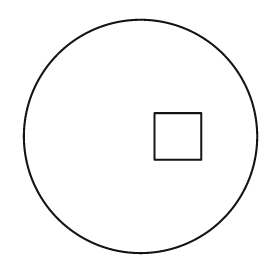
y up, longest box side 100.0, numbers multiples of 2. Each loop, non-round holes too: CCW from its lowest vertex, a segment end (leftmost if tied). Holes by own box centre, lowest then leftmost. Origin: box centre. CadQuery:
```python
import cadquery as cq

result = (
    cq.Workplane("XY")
    .moveTo(0.0, 0.0)
    .circle(50.0)
    .moveTo(6.0, -10.0)
    .lineTo(26.0, -10.0)
    .lineTo(26.0, 10.0)
    .lineTo(6.0, 10.0)
    .close()
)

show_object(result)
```